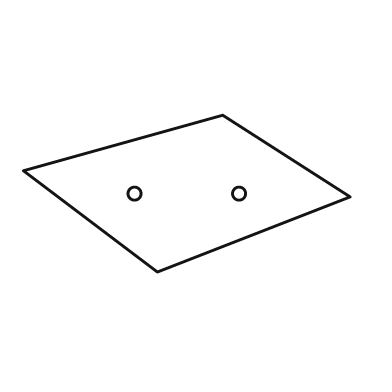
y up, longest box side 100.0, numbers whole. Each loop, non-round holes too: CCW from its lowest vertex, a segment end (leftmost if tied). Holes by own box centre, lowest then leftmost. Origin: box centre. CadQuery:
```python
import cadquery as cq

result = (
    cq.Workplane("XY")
    .moveTo(-9.0, -24.0)
    .lineTo(50.0, -1.0)
    .lineTo(11.0, 24.0)
    .lineTo(-50.0, 7.0)
    .close()
    .moveTo(-16.0, 0.0)
    .circle(2.0)
    .moveTo(16.0, 0.0)
    .circle(2.0)
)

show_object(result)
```